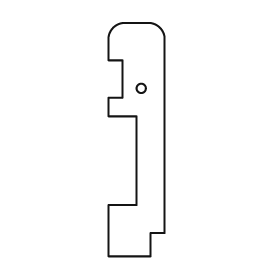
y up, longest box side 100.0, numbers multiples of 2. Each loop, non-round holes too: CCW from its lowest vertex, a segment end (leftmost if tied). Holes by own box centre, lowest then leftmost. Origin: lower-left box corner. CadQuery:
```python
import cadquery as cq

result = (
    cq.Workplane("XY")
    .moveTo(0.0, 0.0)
    .lineTo(18.0, 0.0)
    .lineTo(18.0, 10.0)
    .lineTo(24.0, 10.0)
    .lineTo(24.0, 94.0)
    .threePointArc((22.0, 98.0), (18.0, 100.0))
    .lineTo(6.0, 100.0)
    .threePointArc((2.0, 98.0), (0.0, 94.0))
    .lineTo(0.0, 84.0)
    .lineTo(6.0, 84.0)
    .lineTo(6.0, 68.0)
    .lineTo(0.0, 68.0)
    .lineTo(0.0, 60.0)
    .lineTo(12.0, 60.0)
    .lineTo(12.0, 22.0)
    .lineTo(0.0, 22.0)
    .close()
    .moveTo(14.0, 72.0)
    .circle(2.0)
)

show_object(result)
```